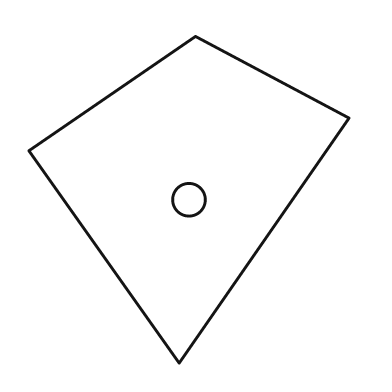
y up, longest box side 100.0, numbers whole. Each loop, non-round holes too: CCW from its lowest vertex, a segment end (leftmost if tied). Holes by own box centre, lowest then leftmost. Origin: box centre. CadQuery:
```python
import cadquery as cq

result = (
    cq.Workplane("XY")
    .moveTo(-3.0, -50.0)
    .lineTo(49.0, 25.0)
    .lineTo(2.0, 50.0)
    .lineTo(-49.0, 15.0)
    .close()
    .moveTo(0.0, 0.0)
    .circle(5.0)
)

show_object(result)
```